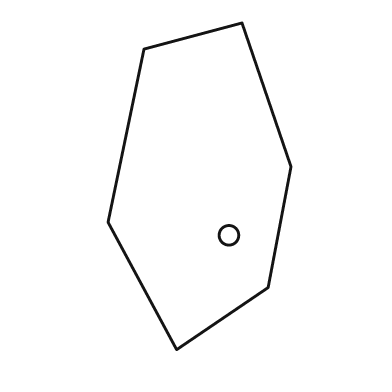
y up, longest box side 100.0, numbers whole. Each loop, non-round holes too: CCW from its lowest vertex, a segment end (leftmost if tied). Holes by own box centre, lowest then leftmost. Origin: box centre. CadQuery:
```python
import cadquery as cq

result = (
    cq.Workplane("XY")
    .moveTo(-7.0, -50.0)
    .lineTo(21.0, -31.0)
    .lineTo(28.0, 6.0)
    .lineTo(13.0, 50.0)
    .lineTo(-17.0, 42.0)
    .lineTo(-28.0, -11.0)
    .close()
    .moveTo(9.0, -15.0)
    .circle(3.0)
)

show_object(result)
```